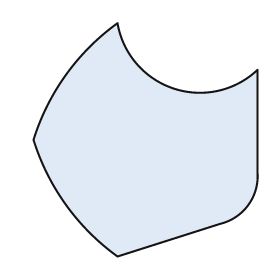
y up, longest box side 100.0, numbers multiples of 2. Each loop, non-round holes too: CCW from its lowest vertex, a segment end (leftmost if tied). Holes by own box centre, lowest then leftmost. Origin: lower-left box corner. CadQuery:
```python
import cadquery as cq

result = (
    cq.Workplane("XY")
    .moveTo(36.0, 0.0)
    .lineTo(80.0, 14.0)
    .threePointArc((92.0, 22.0), (96.0, 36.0))
    .lineTo(96.0, 80.0)
    .threePointArc((60.0, 72.0), (36.0, 100.0))
    .threePointArc((14.0, 78.0), (0.0, 50.0))
    .threePointArc((14.0, 22.0), (36.0, 0.0))
    .close()
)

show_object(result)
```